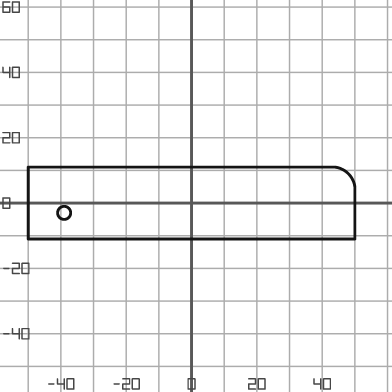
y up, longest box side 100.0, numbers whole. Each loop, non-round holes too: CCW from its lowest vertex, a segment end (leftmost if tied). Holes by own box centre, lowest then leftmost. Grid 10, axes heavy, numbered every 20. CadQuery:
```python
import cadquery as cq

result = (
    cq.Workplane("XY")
    .moveTo(-50.0, -11.0)
    .lineTo(50.0, -11.0)
    .lineTo(50.0, 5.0)
    .threePointArc((48.0, 9.0), (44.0, 11.0))
    .lineTo(-50.0, 11.0)
    .close()
    .moveTo(-39.0, -3.0)
    .circle(2.0)
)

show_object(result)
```